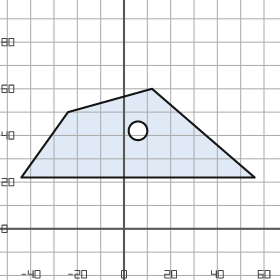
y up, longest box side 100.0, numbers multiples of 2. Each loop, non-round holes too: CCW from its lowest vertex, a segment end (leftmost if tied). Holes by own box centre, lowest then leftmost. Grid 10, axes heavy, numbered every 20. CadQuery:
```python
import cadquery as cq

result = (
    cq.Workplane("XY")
    .moveTo(-44.0, 22.0)
    .lineTo(56.0, 22.0)
    .lineTo(12.0, 60.0)
    .lineTo(-24.0, 50.0)
    .close()
    .moveTo(6.0, 42.0)
    .circle(4.0)
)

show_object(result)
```